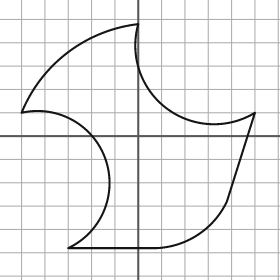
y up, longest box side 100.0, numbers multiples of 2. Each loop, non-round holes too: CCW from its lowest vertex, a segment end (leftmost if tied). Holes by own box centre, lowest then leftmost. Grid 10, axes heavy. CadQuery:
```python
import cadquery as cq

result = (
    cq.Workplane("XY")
    .moveTo(-30.0, -48.0)
    .lineTo(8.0, -48.0)
    .threePointArc((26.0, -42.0), (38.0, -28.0))
    .lineTo(50.0, 10.0)
    .threePointArc((12.0, 12.0), (0.0, 48.0))
    .threePointArc((-30.0, 36.0), (-50.0, 10.0))
    .threePointArc((-14.0, -10.0), (-30.0, -48.0))
    .close()
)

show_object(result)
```